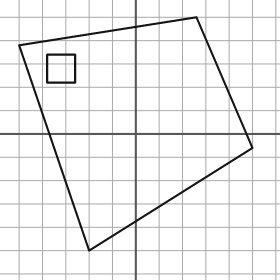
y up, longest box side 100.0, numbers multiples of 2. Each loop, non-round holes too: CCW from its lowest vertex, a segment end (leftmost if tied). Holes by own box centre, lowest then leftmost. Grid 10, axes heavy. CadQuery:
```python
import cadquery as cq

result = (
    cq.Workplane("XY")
    .moveTo(-20.0, -50.0)
    .lineTo(50.0, -6.0)
    .lineTo(26.0, 50.0)
    .lineTo(-50.0, 38.0)
    .close()
    .moveTo(-38.0, 22.0)
    .lineTo(-26.0, 22.0)
    .lineTo(-26.0, 34.0)
    .lineTo(-38.0, 34.0)
    .close()
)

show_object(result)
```